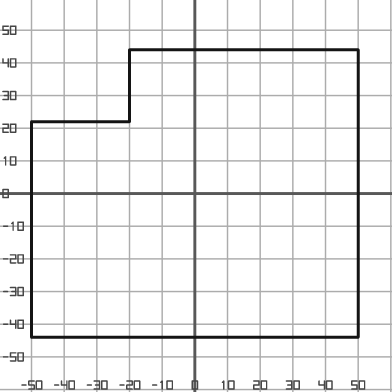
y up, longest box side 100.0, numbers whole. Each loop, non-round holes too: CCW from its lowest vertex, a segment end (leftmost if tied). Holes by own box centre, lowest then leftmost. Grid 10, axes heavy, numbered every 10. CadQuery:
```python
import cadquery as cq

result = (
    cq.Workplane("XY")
    .moveTo(-50.0, -44.0)
    .lineTo(50.0, -44.0)
    .lineTo(50.0, 44.0)
    .lineTo(-20.0, 44.0)
    .lineTo(-20.0, 22.0)
    .lineTo(-50.0, 22.0)
    .close()
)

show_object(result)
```